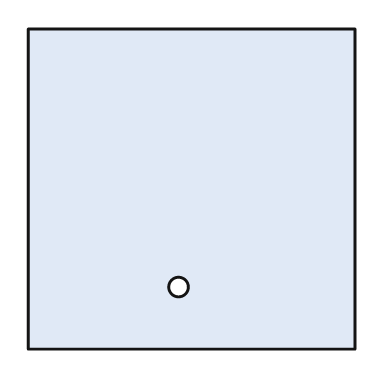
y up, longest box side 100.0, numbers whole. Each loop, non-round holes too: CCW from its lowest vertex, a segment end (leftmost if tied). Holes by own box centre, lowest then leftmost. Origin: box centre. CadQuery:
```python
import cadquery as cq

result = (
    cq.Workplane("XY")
    .moveTo(-50.0, -49.0)
    .lineTo(50.0, -49.0)
    .lineTo(50.0, 49.0)
    .lineTo(-50.0, 49.0)
    .close()
    .moveTo(-4.0, -30.0)
    .circle(3.0)
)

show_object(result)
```